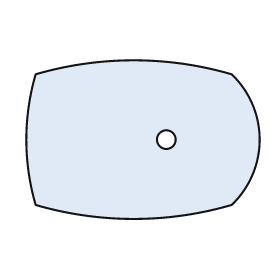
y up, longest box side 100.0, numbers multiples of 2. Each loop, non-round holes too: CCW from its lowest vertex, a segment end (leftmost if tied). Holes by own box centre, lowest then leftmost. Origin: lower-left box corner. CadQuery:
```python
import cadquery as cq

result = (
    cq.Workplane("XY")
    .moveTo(4.0, 6.0)
    .threePointArc((46.0, 0.0), (88.0, 6.0))
    .threePointArc((100.0, 34.0), (88.0, 62.0))
    .threePointArc((46.0, 68.0), (4.0, 62.0))
    .threePointArc((0.0, 34.0), (4.0, 6.0))
    .close()
    .moveTo(60.0, 34.0)
    .circle(4.0)
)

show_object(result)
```